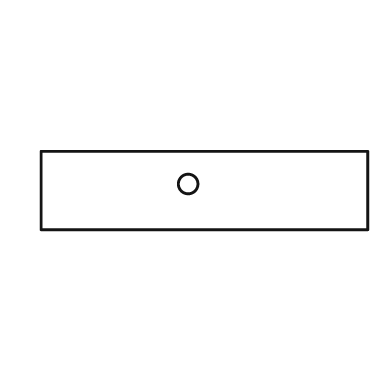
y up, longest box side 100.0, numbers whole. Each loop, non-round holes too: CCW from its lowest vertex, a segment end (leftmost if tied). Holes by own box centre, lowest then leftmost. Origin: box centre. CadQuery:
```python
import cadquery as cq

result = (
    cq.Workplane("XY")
    .moveTo(-50.0, -12.0)
    .lineTo(50.0, -12.0)
    .lineTo(50.0, 12.0)
    .lineTo(-50.0, 12.0)
    .close()
    .moveTo(-5.0, 2.0)
    .circle(3.0)
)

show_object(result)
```